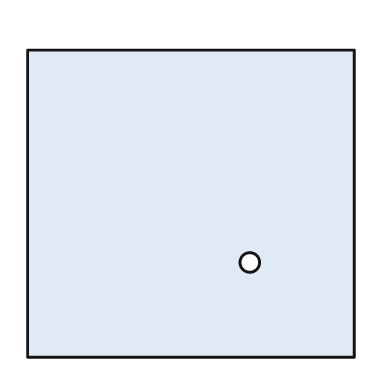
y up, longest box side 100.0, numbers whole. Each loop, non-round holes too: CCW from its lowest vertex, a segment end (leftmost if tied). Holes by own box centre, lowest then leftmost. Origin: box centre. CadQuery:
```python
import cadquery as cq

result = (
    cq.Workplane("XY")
    .moveTo(-50.0, -47.0)
    .lineTo(50.0, -47.0)
    .lineTo(50.0, 47.0)
    .lineTo(-50.0, 47.0)
    .close()
    .moveTo(18.0, -18.0)
    .circle(3.0)
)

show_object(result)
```